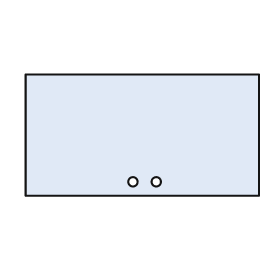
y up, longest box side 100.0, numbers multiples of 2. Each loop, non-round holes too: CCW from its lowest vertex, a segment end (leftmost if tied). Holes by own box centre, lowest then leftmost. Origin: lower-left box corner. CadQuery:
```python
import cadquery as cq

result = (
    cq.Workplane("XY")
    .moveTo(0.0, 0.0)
    .lineTo(100.0, 0.0)
    .lineTo(100.0, 52.0)
    .lineTo(0.0, 52.0)
    .close()
    .moveTo(46.0, 6.0)
    .circle(2.0)
    .moveTo(56.0, 6.0)
    .circle(2.0)
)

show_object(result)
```